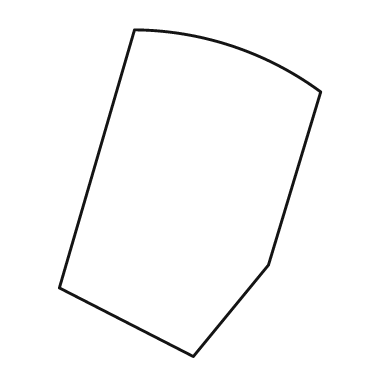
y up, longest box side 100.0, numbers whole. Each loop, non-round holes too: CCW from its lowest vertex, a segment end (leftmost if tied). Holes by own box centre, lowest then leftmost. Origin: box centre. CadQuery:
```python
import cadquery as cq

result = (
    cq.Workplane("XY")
    .moveTo(1.0, -50.0)
    .lineTo(24.0, -22.0)
    .lineTo(40.0, 31.0)
    .threePointArc((13.0, 45.0), (-17.0, 50.0))
    .lineTo(-40.0, -29.0)
    .close()
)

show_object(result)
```